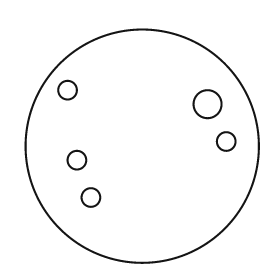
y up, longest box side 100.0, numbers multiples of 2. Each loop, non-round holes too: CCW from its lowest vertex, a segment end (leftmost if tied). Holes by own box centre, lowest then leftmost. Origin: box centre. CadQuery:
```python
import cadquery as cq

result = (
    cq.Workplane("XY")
    .moveTo(0.0, 0.0)
    .circle(50.0)
    .moveTo(-22.0, -22.0)
    .circle(4.0)
    .moveTo(-28.0, -6.0)
    .circle(4.0)
    .moveTo(36.0, 2.0)
    .circle(4.0)
    .moveTo(28.0, 18.0)
    .circle(6.0)
    .moveTo(-32.0, 24.0)
    .circle(4.0)
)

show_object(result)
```